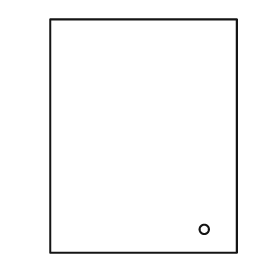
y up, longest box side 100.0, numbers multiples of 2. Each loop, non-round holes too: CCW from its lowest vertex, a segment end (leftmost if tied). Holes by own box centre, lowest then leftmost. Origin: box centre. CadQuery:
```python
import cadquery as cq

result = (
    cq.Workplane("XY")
    .moveTo(-40.0, -50.0)
    .lineTo(40.0, -50.0)
    .lineTo(40.0, 50.0)
    .lineTo(-40.0, 50.0)
    .close()
    .moveTo(26.0, -40.0)
    .circle(2.0)
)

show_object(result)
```